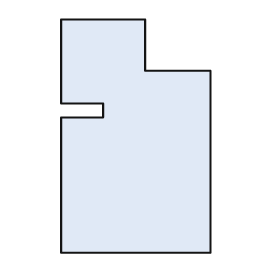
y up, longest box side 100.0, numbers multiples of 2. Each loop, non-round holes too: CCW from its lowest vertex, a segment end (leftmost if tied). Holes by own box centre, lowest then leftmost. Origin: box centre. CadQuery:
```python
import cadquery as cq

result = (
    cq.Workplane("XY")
    .moveTo(-32.0, -50.0)
    .lineTo(32.0, -50.0)
    .lineTo(32.0, 28.0)
    .lineTo(4.0, 28.0)
    .lineTo(4.0, 50.0)
    .lineTo(-32.0, 50.0)
    .lineTo(-32.0, 14.0)
    .lineTo(-14.0, 14.0)
    .lineTo(-14.0, 8.0)
    .lineTo(-32.0, 8.0)
    .close()
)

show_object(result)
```